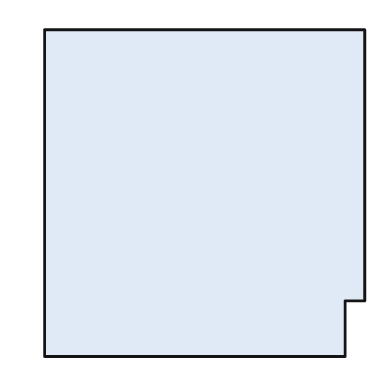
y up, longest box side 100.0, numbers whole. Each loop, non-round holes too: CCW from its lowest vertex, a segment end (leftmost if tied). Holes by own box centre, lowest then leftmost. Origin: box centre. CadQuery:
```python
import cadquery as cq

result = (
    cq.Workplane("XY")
    .moveTo(-49.0, -50.0)
    .lineTo(43.0, -50.0)
    .lineTo(43.0, -33.0)
    .lineTo(49.0, -33.0)
    .lineTo(49.0, 50.0)
    .lineTo(-49.0, 50.0)
    .close()
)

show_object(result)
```